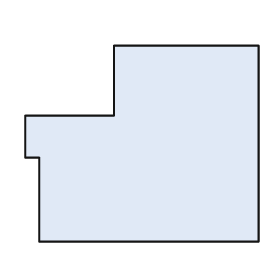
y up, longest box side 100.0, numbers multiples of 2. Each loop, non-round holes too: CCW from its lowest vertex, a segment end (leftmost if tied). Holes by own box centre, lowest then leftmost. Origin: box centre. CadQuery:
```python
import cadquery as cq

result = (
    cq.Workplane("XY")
    .moveTo(-44.0, -42.0)
    .lineTo(50.0, -42.0)
    .lineTo(50.0, 42.0)
    .lineTo(-12.0, 42.0)
    .lineTo(-12.0, 12.0)
    .lineTo(-50.0, 12.0)
    .lineTo(-50.0, -6.0)
    .lineTo(-44.0, -6.0)
    .close()
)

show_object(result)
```